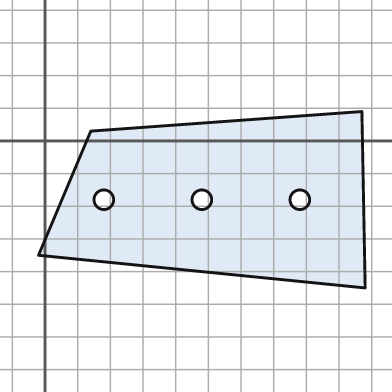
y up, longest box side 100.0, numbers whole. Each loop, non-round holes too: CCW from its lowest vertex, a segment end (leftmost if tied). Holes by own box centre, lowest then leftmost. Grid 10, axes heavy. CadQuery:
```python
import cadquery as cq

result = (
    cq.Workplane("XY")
    .moveTo(98.0, -45.0)
    .lineTo(97.0, 9.0)
    .lineTo(14.0, 3.0)
    .lineTo(-2.0, -35.0)
    .close()
    .moveTo(18.0, -18.0)
    .circle(3.0)
    .moveTo(48.0, -18.0)
    .circle(3.0)
    .moveTo(78.0, -18.0)
    .circle(3.0)
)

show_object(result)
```